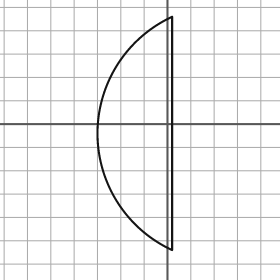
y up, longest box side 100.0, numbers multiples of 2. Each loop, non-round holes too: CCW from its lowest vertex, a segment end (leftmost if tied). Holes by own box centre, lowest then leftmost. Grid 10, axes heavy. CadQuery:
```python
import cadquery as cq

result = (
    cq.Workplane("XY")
    .moveTo(2.0, -54.0)
    .lineTo(2.0, 46.0)
    .threePointArc((-30.0, -4.0), (2.0, -54.0))
    .close()
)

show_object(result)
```